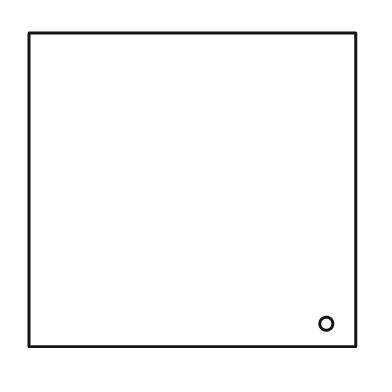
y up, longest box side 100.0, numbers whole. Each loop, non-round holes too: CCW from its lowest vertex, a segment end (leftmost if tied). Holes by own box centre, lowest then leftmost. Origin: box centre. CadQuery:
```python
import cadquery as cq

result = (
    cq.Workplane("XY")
    .moveTo(-50.0, -48.0)
    .lineTo(50.0, -48.0)
    .lineTo(50.0, 48.0)
    .lineTo(-50.0, 48.0)
    .close()
    .moveTo(41.0, -41.0)
    .circle(2.0)
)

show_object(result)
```